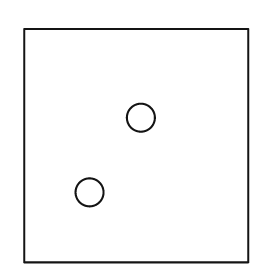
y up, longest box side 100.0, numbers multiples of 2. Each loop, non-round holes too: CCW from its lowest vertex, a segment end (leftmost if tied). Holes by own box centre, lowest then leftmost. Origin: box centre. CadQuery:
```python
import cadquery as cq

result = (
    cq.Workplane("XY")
    .moveTo(-48.0, -50.0)
    .lineTo(48.0, -50.0)
    .lineTo(48.0, 50.0)
    .lineTo(-48.0, 50.0)
    .close()
    .moveTo(-20.0, -20.0)
    .circle(6.0)
    .moveTo(2.0, 12.0)
    .circle(6.0)
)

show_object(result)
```